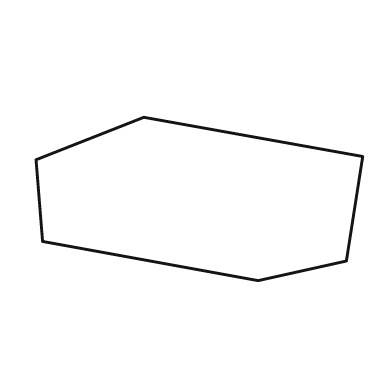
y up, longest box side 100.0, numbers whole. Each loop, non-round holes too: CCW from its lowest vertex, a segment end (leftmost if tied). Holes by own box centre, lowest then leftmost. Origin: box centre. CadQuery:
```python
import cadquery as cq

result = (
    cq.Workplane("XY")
    .moveTo(18.0, -25.0)
    .lineTo(45.0, -19.0)
    .lineTo(50.0, 13.0)
    .lineTo(-17.0, 25.0)
    .lineTo(-50.0, 12.0)
    .lineTo(-48.0, -13.0)
    .close()
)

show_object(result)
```